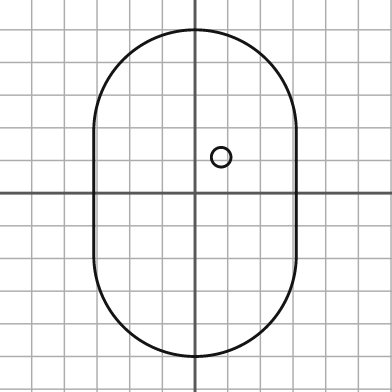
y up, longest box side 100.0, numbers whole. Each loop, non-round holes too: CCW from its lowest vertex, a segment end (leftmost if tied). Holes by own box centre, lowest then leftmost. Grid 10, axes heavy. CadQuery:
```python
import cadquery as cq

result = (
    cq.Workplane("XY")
    .moveTo(-31.0, -19.0)
    .threePointArc((0.0, -50.0), (31.0, -19.0))
    .lineTo(31.0, 19.0)
    .threePointArc((0.0, 50.0), (-31.0, 19.0))
    .close()
    .moveTo(8.0, 11.0)
    .circle(3.0)
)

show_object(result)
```